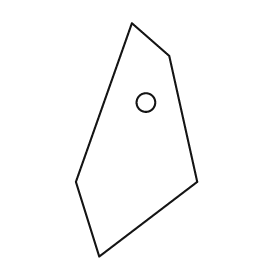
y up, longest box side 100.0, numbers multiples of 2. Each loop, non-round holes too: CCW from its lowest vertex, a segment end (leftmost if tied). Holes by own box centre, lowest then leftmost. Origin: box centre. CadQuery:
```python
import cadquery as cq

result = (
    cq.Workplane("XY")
    .moveTo(-16.0, -50.0)
    .lineTo(26.0, -18.0)
    .lineTo(14.0, 36.0)
    .lineTo(-2.0, 50.0)
    .lineTo(-26.0, -18.0)
    .close()
    .moveTo(4.0, 16.0)
    .circle(4.0)
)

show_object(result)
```